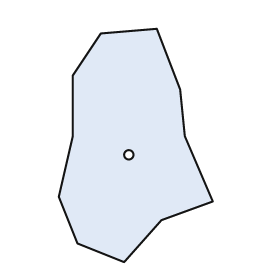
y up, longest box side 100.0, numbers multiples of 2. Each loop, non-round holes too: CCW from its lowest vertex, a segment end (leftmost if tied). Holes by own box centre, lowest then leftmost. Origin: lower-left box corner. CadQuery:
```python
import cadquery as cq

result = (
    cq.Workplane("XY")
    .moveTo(28.0, 0.0)
    .lineTo(44.0, 18.0)
    .lineTo(66.0, 26.0)
    .lineTo(54.0, 54.0)
    .lineTo(52.0, 74.0)
    .lineTo(42.0, 100.0)
    .lineTo(18.0, 98.0)
    .lineTo(6.0, 80.0)
    .lineTo(6.0, 54.0)
    .lineTo(0.0, 28.0)
    .lineTo(8.0, 8.0)
    .close()
    .moveTo(30.0, 46.0)
    .circle(2.0)
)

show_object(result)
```